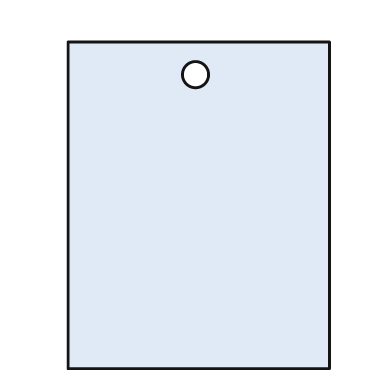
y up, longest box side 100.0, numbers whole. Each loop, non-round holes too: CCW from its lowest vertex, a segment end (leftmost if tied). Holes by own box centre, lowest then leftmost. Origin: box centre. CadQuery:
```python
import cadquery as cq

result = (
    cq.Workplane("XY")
    .moveTo(-40.0, -50.0)
    .lineTo(40.0, -50.0)
    .lineTo(40.0, 50.0)
    .lineTo(-40.0, 50.0)
    .close()
    .moveTo(-1.0, 40.0)
    .circle(4.0)
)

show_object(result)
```